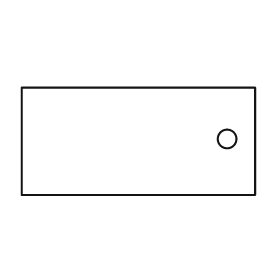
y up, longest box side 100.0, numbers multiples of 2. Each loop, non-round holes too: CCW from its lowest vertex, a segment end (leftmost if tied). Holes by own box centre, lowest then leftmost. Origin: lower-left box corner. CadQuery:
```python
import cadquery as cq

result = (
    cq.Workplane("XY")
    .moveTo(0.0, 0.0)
    .lineTo(100.0, 0.0)
    .lineTo(100.0, 46.0)
    .lineTo(0.0, 46.0)
    .close()
    .moveTo(88.0, 24.0)
    .circle(4.0)
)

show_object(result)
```